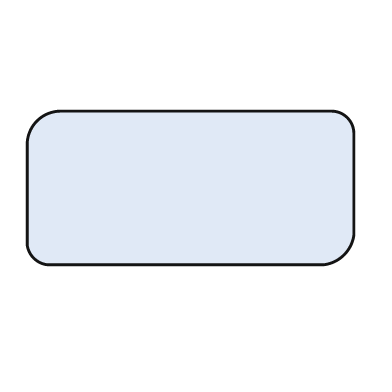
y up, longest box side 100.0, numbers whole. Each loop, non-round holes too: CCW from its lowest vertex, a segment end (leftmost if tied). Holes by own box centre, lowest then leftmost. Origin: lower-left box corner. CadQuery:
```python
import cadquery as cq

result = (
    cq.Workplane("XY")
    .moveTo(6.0, 0.0)
    .lineTo(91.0, 0.0)
    .threePointArc((97.0, 3.0), (100.0, 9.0))
    .lineTo(100.0, 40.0)
    .threePointArc((98.0, 45.0), (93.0, 47.0))
    .lineTo(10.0, 47.0)
    .threePointArc((3.0, 44.0), (0.0, 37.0))
    .lineTo(0.0, 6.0)
    .threePointArc((2.0, 2.0), (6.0, 0.0))
    .close()
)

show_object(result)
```